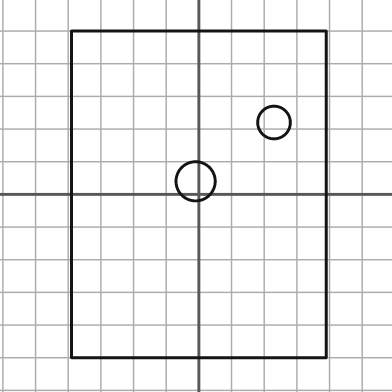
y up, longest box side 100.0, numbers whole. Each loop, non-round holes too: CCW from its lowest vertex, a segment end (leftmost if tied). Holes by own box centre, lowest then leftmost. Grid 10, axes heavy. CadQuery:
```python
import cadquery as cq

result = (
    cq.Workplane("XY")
    .moveTo(-39.0, -50.0)
    .lineTo(39.0, -50.0)
    .lineTo(39.0, 50.0)
    .lineTo(-39.0, 50.0)
    .close()
    .moveTo(-1.0, 4.0)
    .circle(6.0)
    .moveTo(23.0, 22.0)
    .circle(5.0)
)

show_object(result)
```